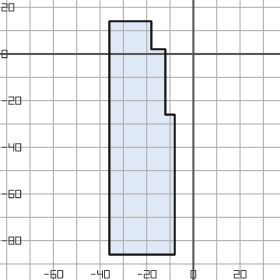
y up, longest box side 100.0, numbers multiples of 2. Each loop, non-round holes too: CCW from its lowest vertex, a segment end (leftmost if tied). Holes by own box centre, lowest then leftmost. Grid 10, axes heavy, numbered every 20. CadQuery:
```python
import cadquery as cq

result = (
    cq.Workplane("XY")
    .moveTo(-36.0, -86.0)
    .lineTo(-8.0, -86.0)
    .lineTo(-8.0, -26.0)
    .lineTo(-12.0, -26.0)
    .lineTo(-12.0, 2.0)
    .lineTo(-18.0, 2.0)
    .lineTo(-18.0, 14.0)
    .lineTo(-36.0, 14.0)
    .close()
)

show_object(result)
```